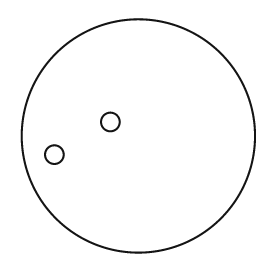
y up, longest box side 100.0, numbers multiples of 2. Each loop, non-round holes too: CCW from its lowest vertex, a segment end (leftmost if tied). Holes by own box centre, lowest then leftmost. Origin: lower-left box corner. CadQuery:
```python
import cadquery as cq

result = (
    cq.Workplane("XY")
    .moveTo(50.0, 50.0)
    .circle(50.0)
    .moveTo(14.0, 42.0)
    .circle(4.0)
    .moveTo(38.0, 56.0)
    .circle(4.0)
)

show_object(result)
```